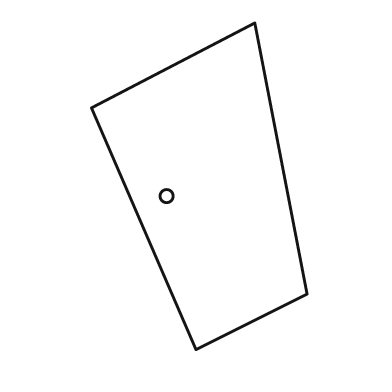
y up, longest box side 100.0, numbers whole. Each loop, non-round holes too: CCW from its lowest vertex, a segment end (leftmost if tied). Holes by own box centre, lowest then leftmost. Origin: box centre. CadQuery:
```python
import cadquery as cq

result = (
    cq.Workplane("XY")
    .moveTo(-1.0, -50.0)
    .lineTo(33.0, -33.0)
    .lineTo(17.0, 50.0)
    .lineTo(-33.0, 24.0)
    .close()
    .moveTo(-10.0, -3.0)
    .circle(2.0)
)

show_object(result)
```